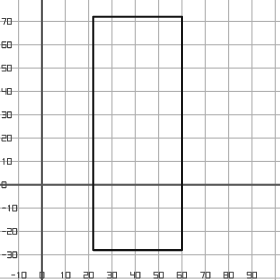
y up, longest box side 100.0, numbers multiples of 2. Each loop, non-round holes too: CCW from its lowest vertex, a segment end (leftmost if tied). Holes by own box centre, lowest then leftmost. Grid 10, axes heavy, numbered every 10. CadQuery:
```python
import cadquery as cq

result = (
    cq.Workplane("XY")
    .moveTo(22.0, -28.0)
    .lineTo(60.0, -28.0)
    .lineTo(60.0, 72.0)
    .lineTo(22.0, 72.0)
    .close()
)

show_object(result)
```